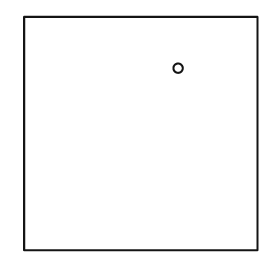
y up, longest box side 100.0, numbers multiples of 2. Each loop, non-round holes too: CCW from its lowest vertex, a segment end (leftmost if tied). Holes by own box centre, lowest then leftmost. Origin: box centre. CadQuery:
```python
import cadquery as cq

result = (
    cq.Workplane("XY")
    .moveTo(-50.0, -50.0)
    .lineTo(50.0, -50.0)
    .lineTo(50.0, 50.0)
    .lineTo(-50.0, 50.0)
    .close()
    .moveTo(16.0, 28.0)
    .circle(2.0)
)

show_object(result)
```